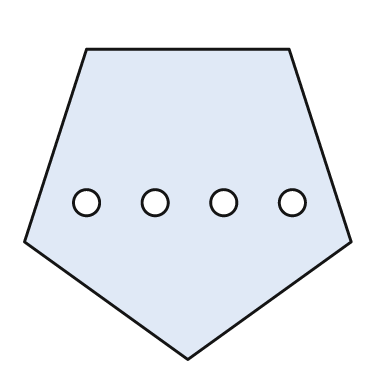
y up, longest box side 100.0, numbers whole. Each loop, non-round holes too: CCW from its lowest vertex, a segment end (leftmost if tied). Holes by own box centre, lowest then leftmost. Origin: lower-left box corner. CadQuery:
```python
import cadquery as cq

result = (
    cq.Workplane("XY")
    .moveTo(50.0, 0.0)
    .lineTo(100.0, 36.0)
    .lineTo(81.0, 95.0)
    .lineTo(19.0, 95.0)
    .lineTo(0.0, 36.0)
    .close()
    .moveTo(19.0, 48.0)
    .circle(4.0)
    .moveTo(40.0, 48.0)
    .circle(4.0)
    .moveTo(61.0, 48.0)
    .circle(4.0)
    .moveTo(82.0, 48.0)
    .circle(4.0)
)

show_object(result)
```